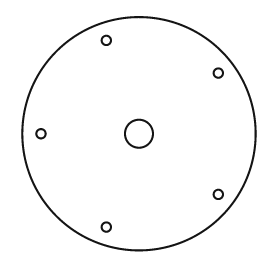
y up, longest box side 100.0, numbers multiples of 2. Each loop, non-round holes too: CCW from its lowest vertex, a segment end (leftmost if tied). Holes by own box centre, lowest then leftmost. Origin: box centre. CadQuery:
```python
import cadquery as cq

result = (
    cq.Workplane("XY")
    .moveTo(0.0, 0.0)
    .circle(50.0)
    .moveTo(-14.0, -40.0)
    .circle(2.0)
    .moveTo(34.0, -26.0)
    .circle(2.0)
    .moveTo(-42.0, 0.0)
    .circle(2.0)
    .moveTo(0.0, 0.0)
    .circle(6.0)
    .moveTo(34.0, 26.0)
    .circle(2.0)
    .moveTo(-14.0, 40.0)
    .circle(2.0)
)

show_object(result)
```